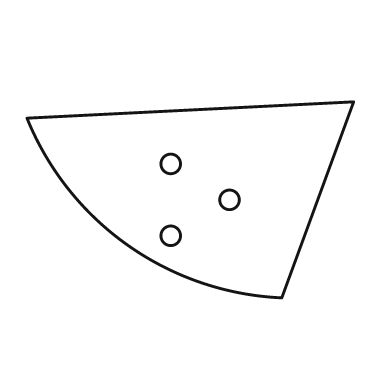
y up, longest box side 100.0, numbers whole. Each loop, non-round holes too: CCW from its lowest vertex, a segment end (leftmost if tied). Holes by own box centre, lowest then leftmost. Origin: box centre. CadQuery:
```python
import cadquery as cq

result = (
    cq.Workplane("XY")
    .moveTo(28.0, -30.0)
    .lineTo(50.0, 30.0)
    .lineTo(-50.0, 25.0)
    .threePointArc((-19.0, -14.0), (28.0, -30.0))
    .close()
    .moveTo(-6.0, -11.0)
    .circle(3.0)
    .moveTo(12.0, 0.0)
    .circle(3.0)
    .moveTo(-6.0, 11.0)
    .circle(3.0)
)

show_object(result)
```